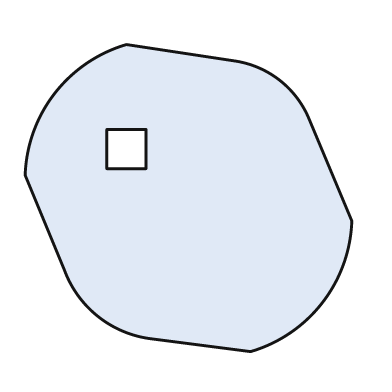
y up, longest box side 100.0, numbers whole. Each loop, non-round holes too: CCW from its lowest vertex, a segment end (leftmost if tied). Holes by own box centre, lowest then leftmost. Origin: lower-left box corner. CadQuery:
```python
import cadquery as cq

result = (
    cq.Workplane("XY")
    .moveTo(69.0, 0.0)
    .threePointArc((91.0, 15.0), (100.0, 40.0))
    .lineTo(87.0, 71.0)
    .threePointArc((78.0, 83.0), (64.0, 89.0))
    .lineTo(31.0, 94.0)
    .threePointArc((9.0, 79.0), (0.0, 54.0))
    .lineTo(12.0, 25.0)
    .threePointArc((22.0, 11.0), (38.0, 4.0))
    .close()
    .moveTo(25.0, 56.0)
    .lineTo(37.0, 56.0)
    .lineTo(37.0, 68.0)
    .lineTo(25.0, 68.0)
    .close()
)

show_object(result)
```